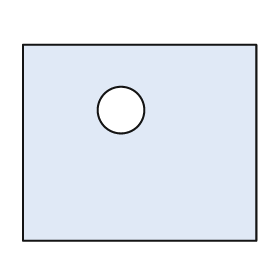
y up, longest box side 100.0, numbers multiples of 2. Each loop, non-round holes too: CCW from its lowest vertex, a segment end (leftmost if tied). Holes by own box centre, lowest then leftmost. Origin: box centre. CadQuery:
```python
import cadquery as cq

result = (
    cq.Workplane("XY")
    .moveTo(-50.0, -42.0)
    .lineTo(50.0, -42.0)
    .lineTo(50.0, 42.0)
    .lineTo(-50.0, 42.0)
    .close()
    .moveTo(-8.0, 14.0)
    .circle(10.0)
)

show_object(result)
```